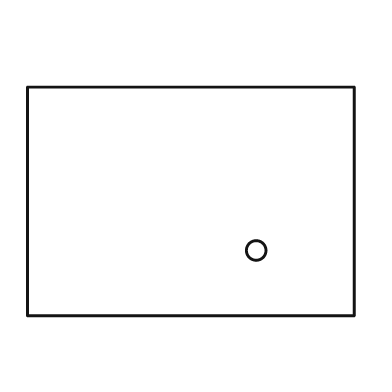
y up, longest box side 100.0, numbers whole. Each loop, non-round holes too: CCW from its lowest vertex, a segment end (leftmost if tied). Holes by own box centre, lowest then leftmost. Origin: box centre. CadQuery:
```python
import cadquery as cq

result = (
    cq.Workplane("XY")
    .moveTo(-50.0, -35.0)
    .lineTo(50.0, -35.0)
    .lineTo(50.0, 35.0)
    .lineTo(-50.0, 35.0)
    .close()
    .moveTo(20.0, -15.0)
    .circle(3.0)
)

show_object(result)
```